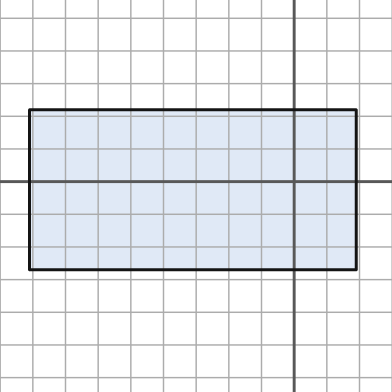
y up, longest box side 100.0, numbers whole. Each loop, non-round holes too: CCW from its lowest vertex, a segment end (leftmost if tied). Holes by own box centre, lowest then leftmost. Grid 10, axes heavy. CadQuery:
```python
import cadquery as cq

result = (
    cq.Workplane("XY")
    .moveTo(-81.0, -27.0)
    .lineTo(19.0, -27.0)
    .lineTo(19.0, 22.0)
    .lineTo(-81.0, 22.0)
    .close()
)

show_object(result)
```